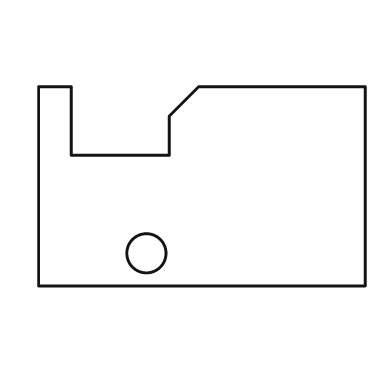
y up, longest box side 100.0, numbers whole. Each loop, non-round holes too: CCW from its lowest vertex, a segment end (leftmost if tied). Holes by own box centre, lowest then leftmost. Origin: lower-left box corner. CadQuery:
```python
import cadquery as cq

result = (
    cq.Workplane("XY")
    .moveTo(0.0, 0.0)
    .lineTo(100.0, 0.0)
    .lineTo(100.0, 61.0)
    .lineTo(49.0, 61.0)
    .lineTo(40.0, 52.0)
    .lineTo(40.0, 40.0)
    .lineTo(10.0, 40.0)
    .lineTo(10.0, 61.0)
    .lineTo(0.0, 61.0)
    .close()
    .moveTo(33.0, 10.0)
    .circle(6.0)
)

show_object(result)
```